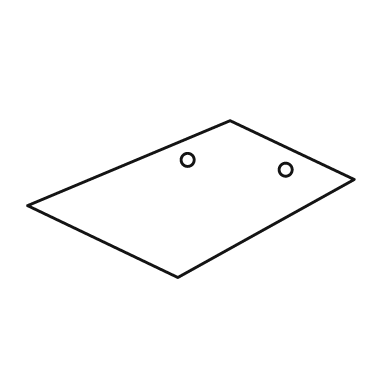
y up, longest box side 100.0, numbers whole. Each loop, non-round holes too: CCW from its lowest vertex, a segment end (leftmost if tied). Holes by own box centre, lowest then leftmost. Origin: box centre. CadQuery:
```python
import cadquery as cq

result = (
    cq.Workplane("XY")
    .moveTo(-4.0, -24.0)
    .lineTo(50.0, 6.0)
    .lineTo(12.0, 24.0)
    .lineTo(-50.0, -2.0)
    .close()
    .moveTo(29.0, 9.0)
    .circle(2.0)
    .moveTo(-1.0, 12.0)
    .circle(2.0)
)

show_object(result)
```